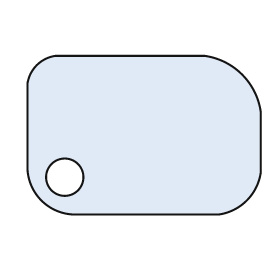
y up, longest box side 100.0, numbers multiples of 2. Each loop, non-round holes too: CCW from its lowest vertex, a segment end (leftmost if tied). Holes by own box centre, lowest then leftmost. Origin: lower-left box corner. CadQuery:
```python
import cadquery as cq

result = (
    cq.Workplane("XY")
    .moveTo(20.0, 0.0)
    .lineTo(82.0, 0.0)
    .threePointArc((94.0, 6.0), (100.0, 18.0))
    .lineTo(100.0, 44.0)
    .threePointArc((92.0, 60.0), (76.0, 68.0))
    .lineTo(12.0, 68.0)
    .threePointArc((4.0, 64.0), (0.0, 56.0))
    .lineTo(0.0, 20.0)
    .threePointArc((6.0, 6.0), (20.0, 0.0))
    .close()
    .moveTo(16.0, 16.0)
    .circle(8.0)
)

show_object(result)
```